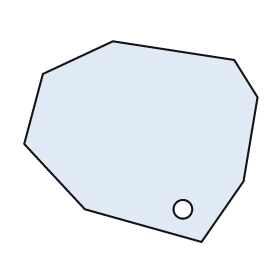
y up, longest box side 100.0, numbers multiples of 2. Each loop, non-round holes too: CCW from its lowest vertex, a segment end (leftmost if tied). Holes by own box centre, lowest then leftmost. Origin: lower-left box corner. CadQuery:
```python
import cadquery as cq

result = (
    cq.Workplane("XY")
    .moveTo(76.0, 0.0)
    .lineTo(94.0, 26.0)
    .lineTo(100.0, 62.0)
    .lineTo(90.0, 78.0)
    .lineTo(38.0, 86.0)
    .lineTo(8.0, 72.0)
    .lineTo(0.0, 42.0)
    .lineTo(26.0, 14.0)
    .close()
    .moveTo(68.0, 14.0)
    .circle(4.0)
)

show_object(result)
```